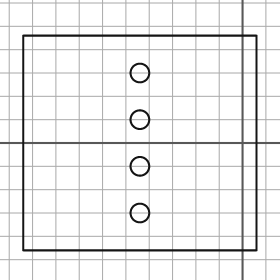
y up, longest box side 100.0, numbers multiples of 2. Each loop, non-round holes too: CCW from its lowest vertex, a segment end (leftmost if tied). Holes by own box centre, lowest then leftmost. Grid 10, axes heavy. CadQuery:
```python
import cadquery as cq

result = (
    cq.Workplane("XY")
    .moveTo(-94.0, -46.0)
    .lineTo(6.0, -46.0)
    .lineTo(6.0, 46.0)
    .lineTo(-94.0, 46.0)
    .close()
    .moveTo(-44.0, -30.0)
    .circle(4.0)
    .moveTo(-44.0, -10.0)
    .circle(4.0)
    .moveTo(-44.0, 10.0)
    .circle(4.0)
    .moveTo(-44.0, 30.0)
    .circle(4.0)
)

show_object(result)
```